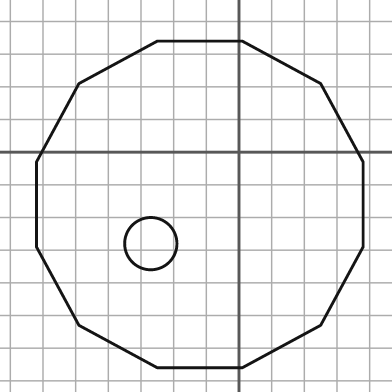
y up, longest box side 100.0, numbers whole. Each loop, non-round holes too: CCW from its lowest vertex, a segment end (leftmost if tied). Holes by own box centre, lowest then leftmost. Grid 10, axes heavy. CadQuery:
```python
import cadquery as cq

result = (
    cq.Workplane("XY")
    .moveTo(-25.0, -66.0)
    .lineTo(1.0, -66.0)
    .lineTo(25.0, -53.0)
    .lineTo(38.0, -29.0)
    .lineTo(38.0, -3.0)
    .lineTo(25.0, 21.0)
    .lineTo(1.0, 34.0)
    .lineTo(-25.0, 34.0)
    .lineTo(-49.0, 21.0)
    .lineTo(-62.0, -3.0)
    .lineTo(-62.0, -29.0)
    .lineTo(-49.0, -53.0)
    .close()
    .moveTo(-27.0, -28.0)
    .circle(8.0)
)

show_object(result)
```